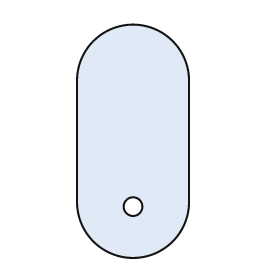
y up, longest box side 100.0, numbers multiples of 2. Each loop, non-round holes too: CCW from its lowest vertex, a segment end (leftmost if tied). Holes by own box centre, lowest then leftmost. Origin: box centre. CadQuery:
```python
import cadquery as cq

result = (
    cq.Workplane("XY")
    .moveTo(-24.0, -26.0)
    .threePointArc((0.0, -50.0), (24.0, -26.0))
    .lineTo(24.0, 26.0)
    .threePointArc((0.0, 50.0), (-24.0, 26.0))
    .close()
    .moveTo(0.0, -28.0)
    .circle(4.0)
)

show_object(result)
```